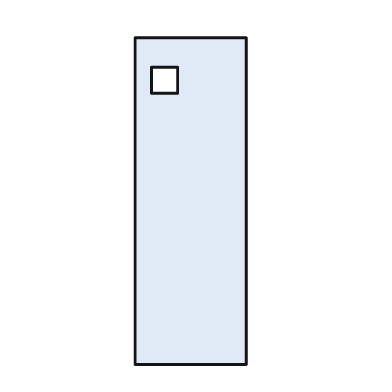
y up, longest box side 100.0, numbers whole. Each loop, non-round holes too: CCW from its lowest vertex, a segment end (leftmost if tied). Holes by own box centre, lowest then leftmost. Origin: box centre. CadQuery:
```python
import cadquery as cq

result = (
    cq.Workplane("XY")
    .moveTo(-17.0, -50.0)
    .lineTo(17.0, -50.0)
    .lineTo(17.0, 50.0)
    .lineTo(-17.0, 50.0)
    .close()
    .moveTo(-12.0, 33.0)
    .lineTo(-4.0, 33.0)
    .lineTo(-4.0, 41.0)
    .lineTo(-12.0, 41.0)
    .close()
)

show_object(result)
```